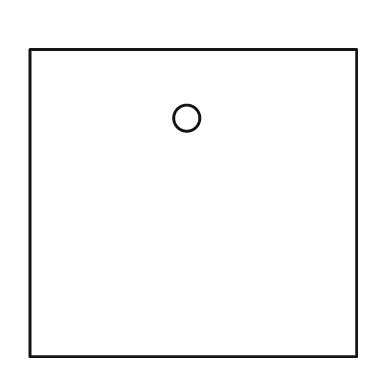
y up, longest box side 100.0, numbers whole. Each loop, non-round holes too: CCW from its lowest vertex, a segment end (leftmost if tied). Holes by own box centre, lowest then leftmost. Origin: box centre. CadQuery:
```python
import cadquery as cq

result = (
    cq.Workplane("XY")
    .moveTo(-50.0, -47.0)
    .lineTo(50.0, -47.0)
    .lineTo(50.0, 47.0)
    .lineTo(-50.0, 47.0)
    .close()
    .moveTo(-2.0, 26.0)
    .circle(4.0)
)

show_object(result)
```